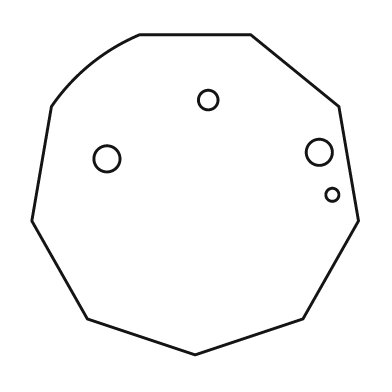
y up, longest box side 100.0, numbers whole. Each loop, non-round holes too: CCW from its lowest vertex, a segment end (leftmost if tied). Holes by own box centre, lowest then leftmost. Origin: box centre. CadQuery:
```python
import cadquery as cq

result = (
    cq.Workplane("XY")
    .moveTo(0.0, -49.0)
    .lineTo(33.0, -38.0)
    .lineTo(50.0, -8.0)
    .lineTo(44.0, 27.0)
    .lineTo(17.0, 49.0)
    .lineTo(-17.0, 49.0)
    .threePointArc((-32.0, 40.0), (-44.0, 27.0))
    .lineTo(-50.0, -8.0)
    .lineTo(-33.0, -38.0)
    .close()
    .moveTo(42.0, 0.0)
    .circle(2.0)
    .moveTo(-27.0, 11.0)
    .circle(4.0)
    .moveTo(38.0, 13.0)
    .circle(4.0)
    .moveTo(4.0, 29.0)
    .circle(3.0)
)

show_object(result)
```